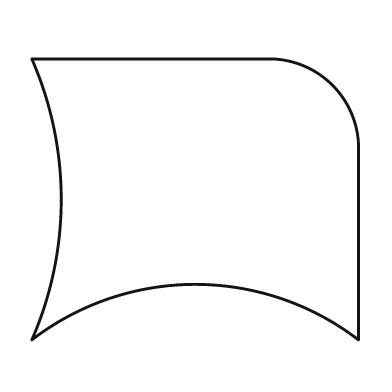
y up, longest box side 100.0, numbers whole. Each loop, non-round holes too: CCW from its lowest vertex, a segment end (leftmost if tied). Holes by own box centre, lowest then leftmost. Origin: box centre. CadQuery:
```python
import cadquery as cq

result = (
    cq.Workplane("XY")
    .moveTo(-50.0, -43.0)
    .threePointArc((0.0, -26.0), (50.0, -43.0))
    .lineTo(50.0, 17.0)
    .threePointArc((42.0, 35.0), (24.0, 43.0))
    .lineTo(-50.0, 43.0)
    .threePointArc((-41.0, 0.0), (-50.0, -43.0))
    .close()
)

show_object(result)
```